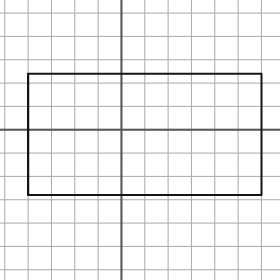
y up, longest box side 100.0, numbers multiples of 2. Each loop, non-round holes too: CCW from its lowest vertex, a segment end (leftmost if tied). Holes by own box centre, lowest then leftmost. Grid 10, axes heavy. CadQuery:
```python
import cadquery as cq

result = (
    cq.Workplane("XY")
    .moveTo(-40.0, -28.0)
    .lineTo(60.0, -28.0)
    .lineTo(60.0, 24.0)
    .lineTo(-40.0, 24.0)
    .close()
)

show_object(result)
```